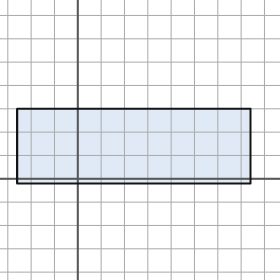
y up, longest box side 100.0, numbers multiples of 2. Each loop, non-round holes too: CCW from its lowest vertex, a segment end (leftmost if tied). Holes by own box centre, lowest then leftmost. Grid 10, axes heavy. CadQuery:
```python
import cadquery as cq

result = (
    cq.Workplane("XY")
    .moveTo(-26.0, -2.0)
    .lineTo(74.0, -2.0)
    .lineTo(74.0, 30.0)
    .lineTo(-26.0, 30.0)
    .close()
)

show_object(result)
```